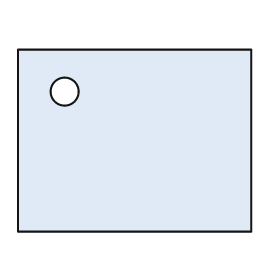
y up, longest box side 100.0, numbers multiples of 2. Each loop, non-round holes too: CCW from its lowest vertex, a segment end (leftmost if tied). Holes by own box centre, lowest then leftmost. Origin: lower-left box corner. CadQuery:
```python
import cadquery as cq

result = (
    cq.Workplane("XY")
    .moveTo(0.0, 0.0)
    .lineTo(100.0, 0.0)
    .lineTo(100.0, 78.0)
    .lineTo(0.0, 78.0)
    .close()
    .moveTo(20.0, 60.0)
    .circle(6.0)
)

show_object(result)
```